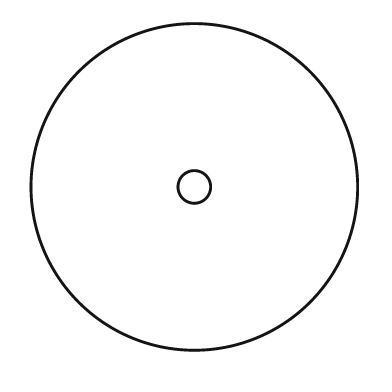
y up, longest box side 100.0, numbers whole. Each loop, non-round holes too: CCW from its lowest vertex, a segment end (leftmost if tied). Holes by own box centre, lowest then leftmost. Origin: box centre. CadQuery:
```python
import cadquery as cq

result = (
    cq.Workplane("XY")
    .moveTo(0.0, 0.0)
    .circle(50.0)
    .moveTo(0.0, 0.0)
    .circle(5.0)
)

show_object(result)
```